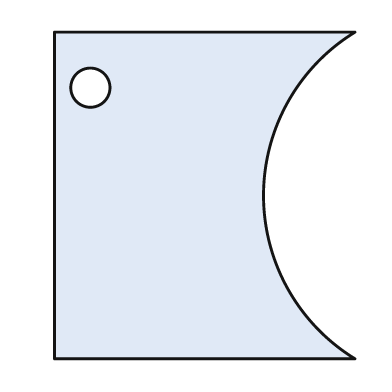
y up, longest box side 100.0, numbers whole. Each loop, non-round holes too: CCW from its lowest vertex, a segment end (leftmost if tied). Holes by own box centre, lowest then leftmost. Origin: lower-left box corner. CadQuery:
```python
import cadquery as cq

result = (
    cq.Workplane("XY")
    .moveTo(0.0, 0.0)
    .lineTo(92.0, 0.0)
    .threePointArc((64.0, 50.0), (92.0, 100.0))
    .lineTo(0.0, 100.0)
    .close()
    .moveTo(11.0, 83.0)
    .circle(6.0)
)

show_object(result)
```